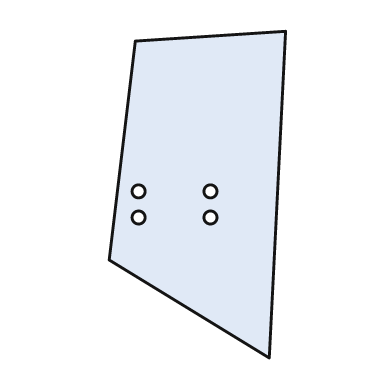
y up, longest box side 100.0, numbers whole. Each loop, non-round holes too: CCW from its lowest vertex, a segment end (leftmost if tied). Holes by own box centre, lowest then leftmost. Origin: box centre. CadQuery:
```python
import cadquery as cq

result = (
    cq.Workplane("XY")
    .moveTo(22.0, -50.0)
    .lineTo(27.0, 50.0)
    .lineTo(-19.0, 47.0)
    .lineTo(-27.0, -20.0)
    .close()
    .moveTo(-18.0, -7.0)
    .circle(2.0)
    .moveTo(4.0, -7.0)
    .circle(2.0)
    .moveTo(-18.0, 1.0)
    .circle(2.0)
    .moveTo(4.0, 1.0)
    .circle(2.0)
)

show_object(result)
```